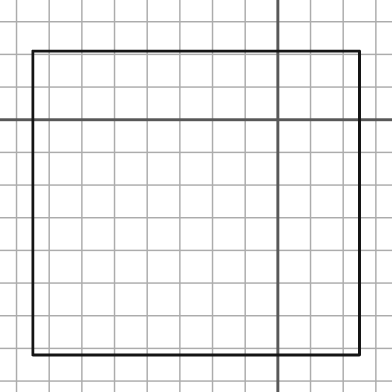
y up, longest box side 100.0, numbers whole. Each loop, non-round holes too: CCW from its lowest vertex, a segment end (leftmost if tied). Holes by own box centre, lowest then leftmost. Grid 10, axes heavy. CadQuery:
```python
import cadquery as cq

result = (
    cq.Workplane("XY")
    .moveTo(-75.0, -72.0)
    .lineTo(25.0, -72.0)
    .lineTo(25.0, 21.0)
    .lineTo(-75.0, 21.0)
    .close()
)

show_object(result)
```